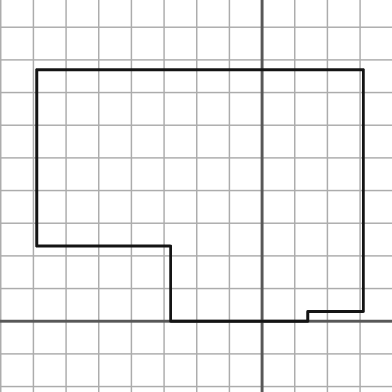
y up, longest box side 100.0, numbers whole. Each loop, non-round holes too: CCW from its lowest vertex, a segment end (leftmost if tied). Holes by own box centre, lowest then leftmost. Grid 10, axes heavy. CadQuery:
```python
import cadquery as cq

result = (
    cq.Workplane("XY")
    .moveTo(-28.0, 0.0)
    .lineTo(14.0, 0.0)
    .lineTo(14.0, 3.0)
    .lineTo(31.0, 3.0)
    .lineTo(31.0, 77.0)
    .lineTo(-69.0, 77.0)
    .lineTo(-69.0, 23.0)
    .lineTo(-28.0, 23.0)
    .close()
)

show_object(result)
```